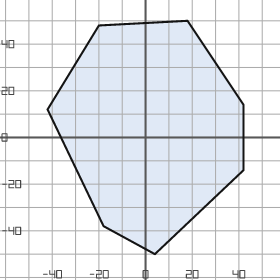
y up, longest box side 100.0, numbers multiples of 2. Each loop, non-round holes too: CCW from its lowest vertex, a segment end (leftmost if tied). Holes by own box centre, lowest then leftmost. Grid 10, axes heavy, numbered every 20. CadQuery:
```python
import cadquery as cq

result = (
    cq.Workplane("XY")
    .moveTo(4.0, -50.0)
    .lineTo(42.0, -14.0)
    .lineTo(42.0, 14.0)
    .lineTo(18.0, 50.0)
    .lineTo(-20.0, 48.0)
    .lineTo(-42.0, 12.0)
    .lineTo(-18.0, -38.0)
    .close()
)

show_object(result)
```